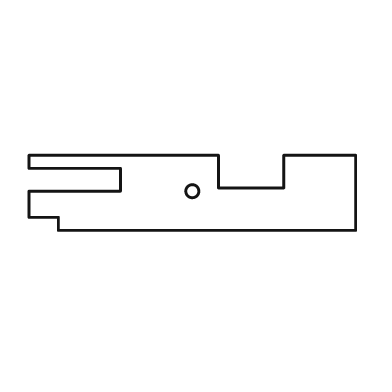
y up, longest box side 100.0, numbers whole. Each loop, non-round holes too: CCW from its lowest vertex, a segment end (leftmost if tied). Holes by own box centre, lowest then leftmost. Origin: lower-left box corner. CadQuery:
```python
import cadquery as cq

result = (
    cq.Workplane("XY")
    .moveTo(9.0, 0.0)
    .lineTo(100.0, 0.0)
    .lineTo(100.0, 23.0)
    .lineTo(78.0, 23.0)
    .lineTo(78.0, 13.0)
    .lineTo(58.0, 13.0)
    .lineTo(58.0, 23.0)
    .lineTo(0.0, 23.0)
    .lineTo(0.0, 19.0)
    .lineTo(28.0, 19.0)
    .lineTo(28.0, 12.0)
    .lineTo(0.0, 12.0)
    .lineTo(0.0, 4.0)
    .lineTo(9.0, 4.0)
    .close()
    .moveTo(50.0, 12.0)
    .circle(2.0)
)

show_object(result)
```